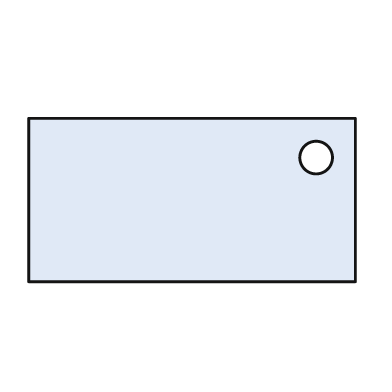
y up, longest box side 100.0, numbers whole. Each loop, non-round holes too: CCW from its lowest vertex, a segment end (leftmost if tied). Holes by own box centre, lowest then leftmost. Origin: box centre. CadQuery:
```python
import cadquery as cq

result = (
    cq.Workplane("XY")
    .moveTo(-50.0, -25.0)
    .lineTo(50.0, -25.0)
    .lineTo(50.0, 25.0)
    .lineTo(-50.0, 25.0)
    .close()
    .moveTo(38.0, 13.0)
    .circle(5.0)
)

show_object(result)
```